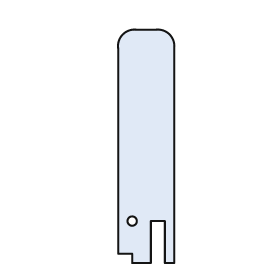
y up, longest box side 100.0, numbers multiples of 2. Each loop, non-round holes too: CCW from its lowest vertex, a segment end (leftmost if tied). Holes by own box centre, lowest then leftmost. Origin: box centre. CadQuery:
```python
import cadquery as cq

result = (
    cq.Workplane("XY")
    .moveTo(-6.0, -50.0)
    .lineTo(2.0, -50.0)
    .lineTo(2.0, -32.0)
    .lineTo(8.0, -32.0)
    .lineTo(8.0, -50.0)
    .lineTo(12.0, -50.0)
    .lineTo(12.0, 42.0)
    .threePointArc((10.0, 48.0), (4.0, 50.0))
    .lineTo(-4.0, 50.0)
    .threePointArc((-10.0, 48.0), (-12.0, 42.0))
    .lineTo(-12.0, -46.0)
    .lineTo(-6.0, -46.0)
    .close()
    .moveTo(-6.0, -32.0)
    .circle(2.0)
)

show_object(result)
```